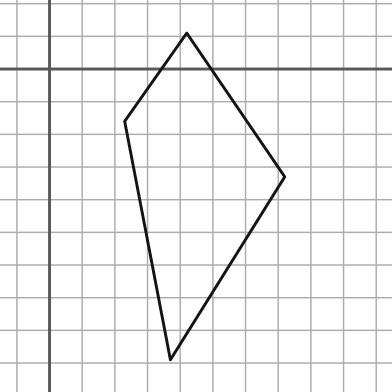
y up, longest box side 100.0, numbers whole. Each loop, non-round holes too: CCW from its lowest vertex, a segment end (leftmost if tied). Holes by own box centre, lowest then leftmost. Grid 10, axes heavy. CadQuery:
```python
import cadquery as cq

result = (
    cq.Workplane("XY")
    .moveTo(37.0, -89.0)
    .lineTo(72.0, -33.0)
    .lineTo(42.0, 11.0)
    .lineTo(23.0, -16.0)
    .close()
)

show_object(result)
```